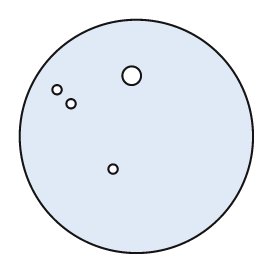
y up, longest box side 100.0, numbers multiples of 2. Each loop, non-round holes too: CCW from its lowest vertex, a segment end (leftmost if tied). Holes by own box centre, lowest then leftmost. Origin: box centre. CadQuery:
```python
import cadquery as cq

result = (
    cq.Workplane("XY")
    .moveTo(0.0, 0.0)
    .circle(50.0)
    .moveTo(-10.0, -14.0)
    .circle(2.0)
    .moveTo(-28.0, 14.0)
    .circle(2.0)
    .moveTo(-34.0, 20.0)
    .circle(2.0)
    .moveTo(-2.0, 26.0)
    .circle(4.0)
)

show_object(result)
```